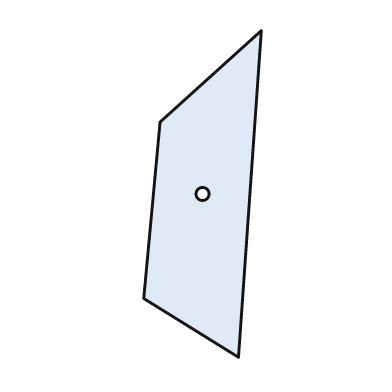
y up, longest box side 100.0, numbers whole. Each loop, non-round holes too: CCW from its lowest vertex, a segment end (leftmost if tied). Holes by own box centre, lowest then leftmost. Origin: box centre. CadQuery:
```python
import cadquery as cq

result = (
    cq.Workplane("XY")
    .moveTo(11.0, -50.0)
    .lineTo(18.0, 50.0)
    .lineTo(-13.0, 22.0)
    .lineTo(-18.0, -32.0)
    .close()
    .moveTo(0.0, 0.0)
    .circle(2.0)
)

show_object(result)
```